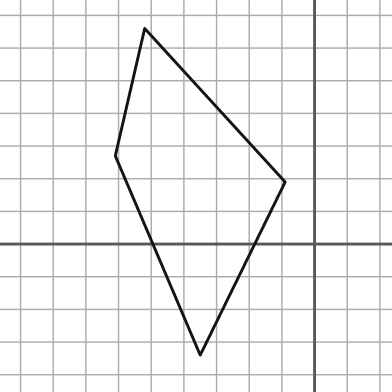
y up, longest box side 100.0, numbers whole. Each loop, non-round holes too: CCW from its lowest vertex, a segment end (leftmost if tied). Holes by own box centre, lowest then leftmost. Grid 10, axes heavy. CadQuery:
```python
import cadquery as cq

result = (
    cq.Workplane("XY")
    .moveTo(-35.0, -34.0)
    .lineTo(-9.0, 19.0)
    .lineTo(-52.0, 66.0)
    .lineTo(-61.0, 27.0)
    .close()
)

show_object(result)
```